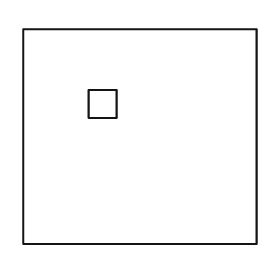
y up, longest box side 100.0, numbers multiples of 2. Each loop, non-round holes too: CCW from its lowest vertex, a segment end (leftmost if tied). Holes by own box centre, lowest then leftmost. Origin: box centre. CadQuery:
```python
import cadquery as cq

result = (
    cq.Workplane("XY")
    .moveTo(-50.0, -46.0)
    .lineTo(50.0, -46.0)
    .lineTo(50.0, 46.0)
    .lineTo(-50.0, 46.0)
    .close()
    .moveTo(-22.0, 8.0)
    .lineTo(-10.0, 8.0)
    .lineTo(-10.0, 20.0)
    .lineTo(-22.0, 20.0)
    .close()
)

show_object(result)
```